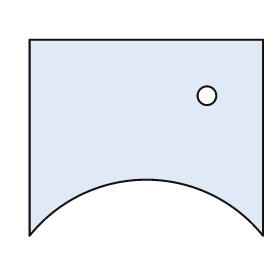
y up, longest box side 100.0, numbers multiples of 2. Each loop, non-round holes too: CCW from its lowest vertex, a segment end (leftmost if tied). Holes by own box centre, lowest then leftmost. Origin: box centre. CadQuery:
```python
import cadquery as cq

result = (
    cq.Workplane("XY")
    .moveTo(-50.0, -42.0)
    .threePointArc((0.0, -18.0), (50.0, -42.0))
    .lineTo(50.0, 42.0)
    .lineTo(-50.0, 42.0)
    .close()
    .moveTo(26.0, 18.0)
    .circle(4.0)
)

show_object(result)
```